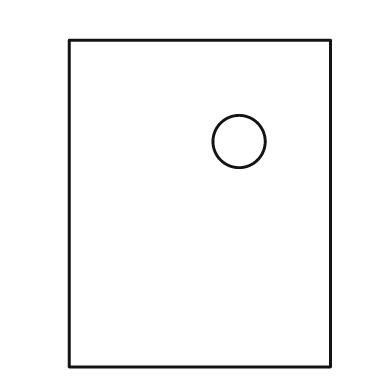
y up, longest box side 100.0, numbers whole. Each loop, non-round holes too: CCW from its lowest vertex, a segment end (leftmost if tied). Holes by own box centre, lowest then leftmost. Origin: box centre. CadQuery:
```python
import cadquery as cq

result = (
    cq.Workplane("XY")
    .moveTo(-40.0, -50.0)
    .lineTo(40.0, -50.0)
    .lineTo(40.0, 50.0)
    .lineTo(-40.0, 50.0)
    .close()
    .moveTo(12.0, 19.0)
    .circle(8.0)
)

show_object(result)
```